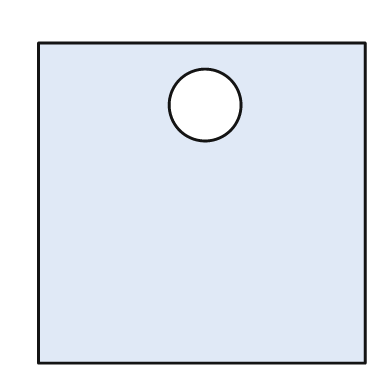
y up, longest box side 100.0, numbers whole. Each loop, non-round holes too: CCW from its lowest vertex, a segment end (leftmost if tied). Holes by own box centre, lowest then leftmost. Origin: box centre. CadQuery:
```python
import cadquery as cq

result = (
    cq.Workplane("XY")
    .moveTo(-50.0, -49.0)
    .lineTo(50.0, -49.0)
    .lineTo(50.0, 49.0)
    .lineTo(-50.0, 49.0)
    .close()
    .moveTo(1.0, 30.0)
    .circle(11.0)
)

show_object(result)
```